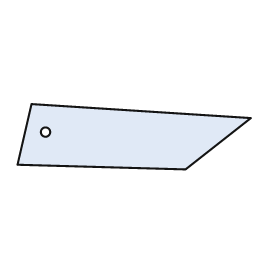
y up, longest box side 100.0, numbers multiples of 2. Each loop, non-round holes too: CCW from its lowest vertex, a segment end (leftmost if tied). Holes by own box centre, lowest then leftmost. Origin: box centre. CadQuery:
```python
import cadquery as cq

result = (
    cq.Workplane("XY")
    .moveTo(22.0, -14.0)
    .lineTo(50.0, 8.0)
    .lineTo(-44.0, 14.0)
    .lineTo(-50.0, -12.0)
    .close()
    .moveTo(-38.0, 2.0)
    .circle(2.0)
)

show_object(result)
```